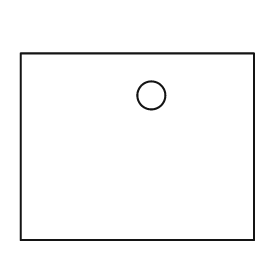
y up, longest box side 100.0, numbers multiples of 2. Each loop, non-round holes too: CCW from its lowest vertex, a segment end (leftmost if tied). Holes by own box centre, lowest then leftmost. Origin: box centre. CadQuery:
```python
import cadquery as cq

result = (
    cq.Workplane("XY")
    .moveTo(-50.0, -40.0)
    .lineTo(50.0, -40.0)
    .lineTo(50.0, 40.0)
    .lineTo(-50.0, 40.0)
    .close()
    .moveTo(6.0, 22.0)
    .circle(6.0)
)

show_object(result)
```